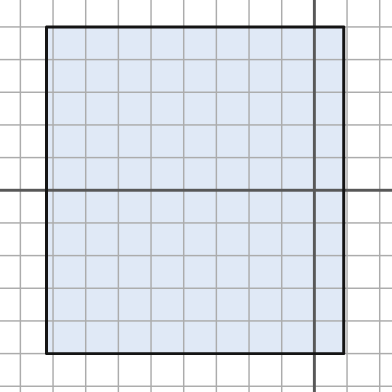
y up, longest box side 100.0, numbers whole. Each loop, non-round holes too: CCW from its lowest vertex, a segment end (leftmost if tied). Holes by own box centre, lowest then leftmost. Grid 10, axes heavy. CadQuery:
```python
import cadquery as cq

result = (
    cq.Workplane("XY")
    .moveTo(-82.0, -50.0)
    .lineTo(9.0, -50.0)
    .lineTo(9.0, 50.0)
    .lineTo(-82.0, 50.0)
    .close()
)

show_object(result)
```